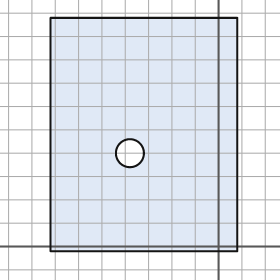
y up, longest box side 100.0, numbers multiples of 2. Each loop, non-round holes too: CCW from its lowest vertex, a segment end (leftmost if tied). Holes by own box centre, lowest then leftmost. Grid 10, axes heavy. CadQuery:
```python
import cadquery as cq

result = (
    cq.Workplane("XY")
    .moveTo(-72.0, -2.0)
    .lineTo(8.0, -2.0)
    .lineTo(8.0, 98.0)
    .lineTo(-72.0, 98.0)
    .close()
    .moveTo(-38.0, 40.0)
    .circle(6.0)
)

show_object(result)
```